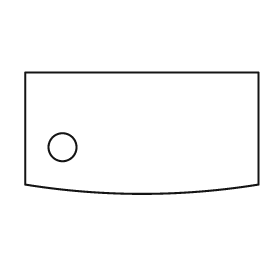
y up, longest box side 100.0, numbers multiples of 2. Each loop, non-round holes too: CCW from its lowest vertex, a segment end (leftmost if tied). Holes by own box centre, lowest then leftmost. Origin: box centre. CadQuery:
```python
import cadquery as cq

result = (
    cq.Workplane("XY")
    .moveTo(-50.0, -22.0)
    .threePointArc((0.0, -26.0), (50.0, -22.0))
    .lineTo(50.0, 26.0)
    .lineTo(-50.0, 26.0)
    .close()
    .moveTo(-34.0, -6.0)
    .circle(6.0)
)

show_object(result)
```